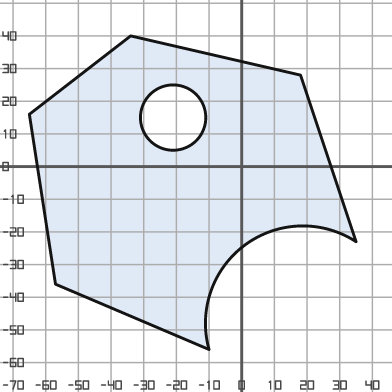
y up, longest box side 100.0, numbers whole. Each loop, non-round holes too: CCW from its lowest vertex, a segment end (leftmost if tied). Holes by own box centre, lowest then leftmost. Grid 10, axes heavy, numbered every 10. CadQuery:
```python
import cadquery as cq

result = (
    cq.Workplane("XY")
    .moveTo(-10.0, -56.0)
    .threePointArc((1.0, -24.0), (35.0, -23.0))
    .lineTo(18.0, 28.0)
    .lineTo(-34.0, 40.0)
    .lineTo(-65.0, 16.0)
    .lineTo(-57.0, -36.0)
    .close()
    .moveTo(-21.0, 15.0)
    .circle(10.0)
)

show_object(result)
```